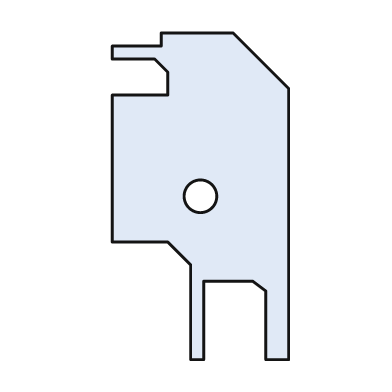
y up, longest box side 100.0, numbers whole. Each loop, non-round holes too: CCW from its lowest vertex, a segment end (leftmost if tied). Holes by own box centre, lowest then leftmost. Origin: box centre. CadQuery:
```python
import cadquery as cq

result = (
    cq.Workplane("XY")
    .moveTo(-3.0, -50.0)
    .lineTo(1.0, -50.0)
    .lineTo(1.0, -26.0)
    .lineTo(16.0, -26.0)
    .lineTo(20.0, -29.0)
    .lineTo(20.0, -50.0)
    .lineTo(27.0, -50.0)
    .lineTo(27.0, 33.0)
    .lineTo(10.0, 50.0)
    .lineTo(-12.0, 50.0)
    .lineTo(-12.0, 46.0)
    .lineTo(-27.0, 46.0)
    .lineTo(-27.0, 42.0)
    .lineTo(-14.0, 42.0)
    .lineTo(-10.0, 38.0)
    .lineTo(-10.0, 31.0)
    .lineTo(-27.0, 31.0)
    .lineTo(-27.0, -14.0)
    .lineTo(-10.0, -14.0)
    .lineTo(-3.0, -21.0)
    .close()
    .moveTo(0.0, 0.0)
    .circle(5.0)
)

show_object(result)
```